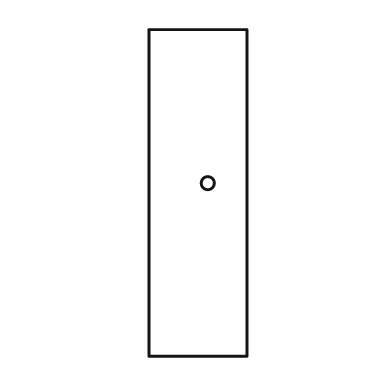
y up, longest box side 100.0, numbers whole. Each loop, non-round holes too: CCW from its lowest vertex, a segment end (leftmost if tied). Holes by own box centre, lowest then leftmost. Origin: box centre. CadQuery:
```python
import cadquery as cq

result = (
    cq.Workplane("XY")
    .moveTo(-15.0, -50.0)
    .lineTo(15.0, -50.0)
    .lineTo(15.0, 50.0)
    .lineTo(-15.0, 50.0)
    .close()
    .moveTo(3.0, 3.0)
    .circle(2.0)
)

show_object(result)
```